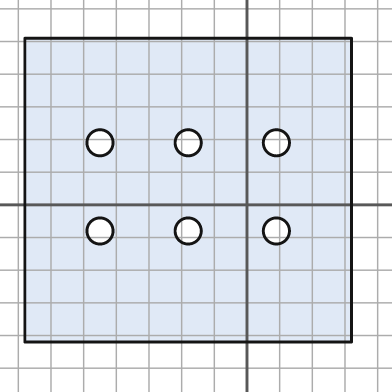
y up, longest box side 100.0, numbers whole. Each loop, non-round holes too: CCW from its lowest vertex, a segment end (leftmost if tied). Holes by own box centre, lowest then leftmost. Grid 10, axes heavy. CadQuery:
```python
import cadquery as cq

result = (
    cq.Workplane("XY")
    .moveTo(-68.0, -42.0)
    .lineTo(32.0, -42.0)
    .lineTo(32.0, 51.0)
    .lineTo(-68.0, 51.0)
    .close()
    .moveTo(-45.0, -8.0)
    .circle(4.0)
    .moveTo(-18.0, -8.0)
    .circle(4.0)
    .moveTo(9.0, -8.0)
    .circle(4.0)
    .moveTo(-45.0, 19.0)
    .circle(4.0)
    .moveTo(-18.0, 19.0)
    .circle(4.0)
    .moveTo(9.0, 19.0)
    .circle(4.0)
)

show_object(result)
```